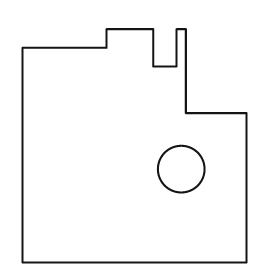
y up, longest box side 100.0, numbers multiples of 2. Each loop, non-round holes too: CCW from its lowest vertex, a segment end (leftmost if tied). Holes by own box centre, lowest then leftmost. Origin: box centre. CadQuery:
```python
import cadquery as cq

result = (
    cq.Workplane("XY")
    .moveTo(-48.0, -50.0)
    .lineTo(48.0, -50.0)
    .lineTo(48.0, 14.0)
    .lineTo(22.0, 14.0)
    .lineTo(22.0, 50.0)
    .lineTo(18.0, 50.0)
    .lineTo(18.0, 34.0)
    .lineTo(8.0, 34.0)
    .lineTo(8.0, 50.0)
    .lineTo(-12.0, 50.0)
    .lineTo(-12.0, 42.0)
    .lineTo(-48.0, 42.0)
    .close()
    .moveTo(20.0, -10.0)
    .circle(10.0)
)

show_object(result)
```